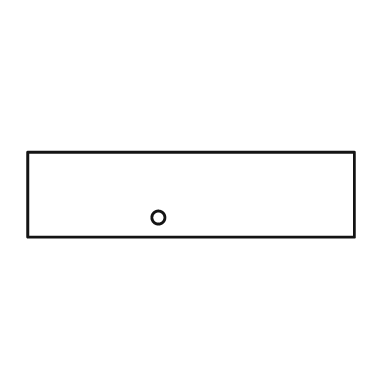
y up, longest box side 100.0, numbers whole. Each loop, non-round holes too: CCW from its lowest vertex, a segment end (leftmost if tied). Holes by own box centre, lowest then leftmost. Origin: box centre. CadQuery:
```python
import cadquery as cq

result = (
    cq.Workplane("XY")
    .moveTo(-50.0, -13.0)
    .lineTo(50.0, -13.0)
    .lineTo(50.0, 13.0)
    .lineTo(-50.0, 13.0)
    .close()
    .moveTo(-10.0, -7.0)
    .circle(2.0)
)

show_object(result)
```